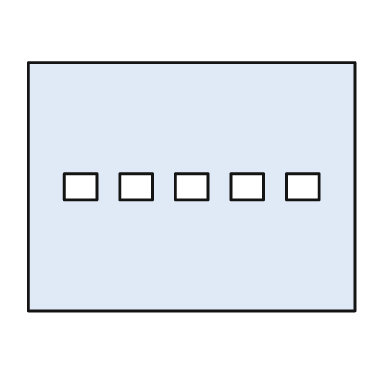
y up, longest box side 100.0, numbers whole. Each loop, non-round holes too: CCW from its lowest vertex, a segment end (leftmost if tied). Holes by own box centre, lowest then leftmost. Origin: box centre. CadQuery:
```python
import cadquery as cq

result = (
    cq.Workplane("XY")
    .moveTo(-50.0, -38.0)
    .lineTo(50.0, -38.0)
    .lineTo(50.0, 38.0)
    .lineTo(-50.0, 38.0)
    .close()
    .moveTo(-39.0, -4.0)
    .lineTo(-29.0, -4.0)
    .lineTo(-29.0, 4.0)
    .lineTo(-39.0, 4.0)
    .close()
    .moveTo(-22.0, -4.0)
    .lineTo(-12.0, -4.0)
    .lineTo(-12.0, 4.0)
    .lineTo(-22.0, 4.0)
    .close()
    .moveTo(-5.0, -4.0)
    .lineTo(5.0, -4.0)
    .lineTo(5.0, 4.0)
    .lineTo(-5.0, 4.0)
    .close()
    .moveTo(12.0, -4.0)
    .lineTo(22.0, -4.0)
    .lineTo(22.0, 4.0)
    .lineTo(12.0, 4.0)
    .close()
    .moveTo(29.0, -4.0)
    .lineTo(39.0, -4.0)
    .lineTo(39.0, 4.0)
    .lineTo(29.0, 4.0)
    .close()
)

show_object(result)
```